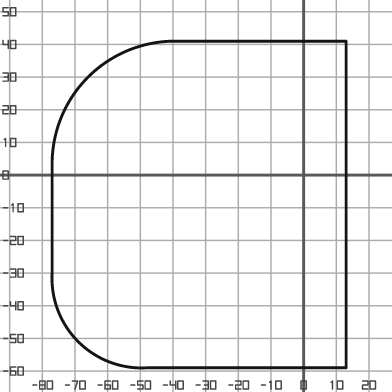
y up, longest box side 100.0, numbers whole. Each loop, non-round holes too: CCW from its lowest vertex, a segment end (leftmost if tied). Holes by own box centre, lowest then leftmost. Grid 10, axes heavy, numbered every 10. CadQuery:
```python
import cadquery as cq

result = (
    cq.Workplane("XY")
    .moveTo(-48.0, -59.0)
    .lineTo(13.0, -59.0)
    .lineTo(13.0, 41.0)
    .lineTo(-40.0, 41.0)
    .threePointArc((-66.0, 30.0), (-77.0, 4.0))
    .lineTo(-77.0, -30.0)
    .threePointArc((-69.0, -51.0), (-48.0, -59.0))
    .close()
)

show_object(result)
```